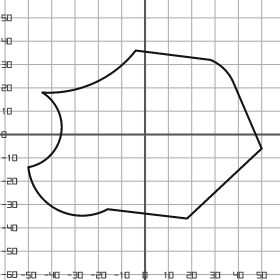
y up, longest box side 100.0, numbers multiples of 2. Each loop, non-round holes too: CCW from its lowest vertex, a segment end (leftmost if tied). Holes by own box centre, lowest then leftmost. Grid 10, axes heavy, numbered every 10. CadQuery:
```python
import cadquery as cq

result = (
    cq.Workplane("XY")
    .moveTo(18.0, -36.0)
    .lineTo(50.0, -6.0)
    .lineTo(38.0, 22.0)
    .threePointArc((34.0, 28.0), (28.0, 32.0))
    .lineTo(-4.0, 36.0)
    .threePointArc((-22.0, 22.0), (-44.0, 18.0))
    .threePointArc((-36.0, 0.0), (-50.0, -14.0))
    .threePointArc((-38.0, -32.0), (-16.0, -32.0))
    .close()
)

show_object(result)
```